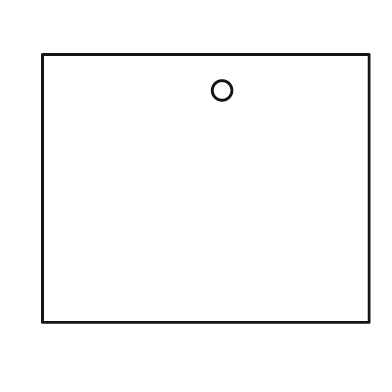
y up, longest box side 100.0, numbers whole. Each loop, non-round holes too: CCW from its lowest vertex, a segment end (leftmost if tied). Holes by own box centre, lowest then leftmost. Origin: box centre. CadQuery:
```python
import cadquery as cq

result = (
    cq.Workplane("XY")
    .moveTo(-50.0, -41.0)
    .lineTo(50.0, -41.0)
    .lineTo(50.0, 41.0)
    .lineTo(-50.0, 41.0)
    .close()
    .moveTo(5.0, 30.0)
    .circle(3.0)
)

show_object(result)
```